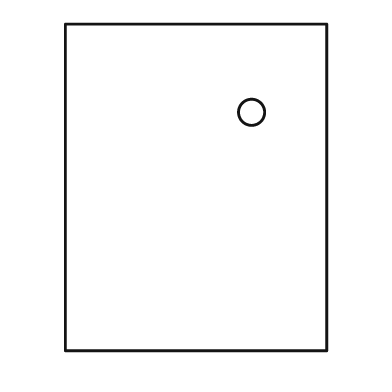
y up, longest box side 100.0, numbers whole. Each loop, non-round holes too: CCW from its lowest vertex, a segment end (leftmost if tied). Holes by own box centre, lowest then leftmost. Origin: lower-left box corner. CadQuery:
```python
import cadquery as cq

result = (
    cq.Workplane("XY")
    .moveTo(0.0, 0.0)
    .lineTo(80.0, 0.0)
    .lineTo(80.0, 100.0)
    .lineTo(0.0, 100.0)
    .close()
    .moveTo(57.0, 73.0)
    .circle(4.0)
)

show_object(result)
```